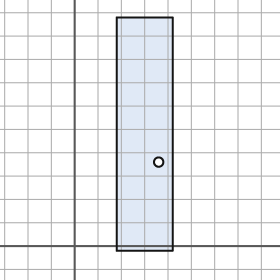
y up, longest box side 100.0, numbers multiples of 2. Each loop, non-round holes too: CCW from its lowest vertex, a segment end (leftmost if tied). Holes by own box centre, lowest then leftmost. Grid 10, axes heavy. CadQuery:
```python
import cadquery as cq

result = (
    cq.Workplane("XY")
    .moveTo(18.0, -2.0)
    .lineTo(42.0, -2.0)
    .lineTo(42.0, 98.0)
    .lineTo(18.0, 98.0)
    .close()
    .moveTo(36.0, 36.0)
    .circle(2.0)
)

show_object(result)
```